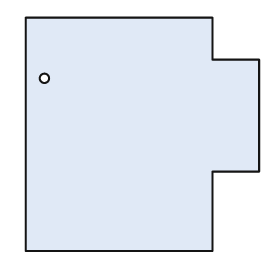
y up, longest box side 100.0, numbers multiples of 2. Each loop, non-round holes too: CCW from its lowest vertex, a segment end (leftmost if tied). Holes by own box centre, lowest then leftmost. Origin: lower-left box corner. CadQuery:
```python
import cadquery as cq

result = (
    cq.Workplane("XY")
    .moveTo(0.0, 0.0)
    .lineTo(80.0, 0.0)
    .lineTo(80.0, 34.0)
    .lineTo(100.0, 34.0)
    .lineTo(100.0, 82.0)
    .lineTo(80.0, 82.0)
    .lineTo(80.0, 100.0)
    .lineTo(0.0, 100.0)
    .close()
    .moveTo(8.0, 74.0)
    .circle(2.0)
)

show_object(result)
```